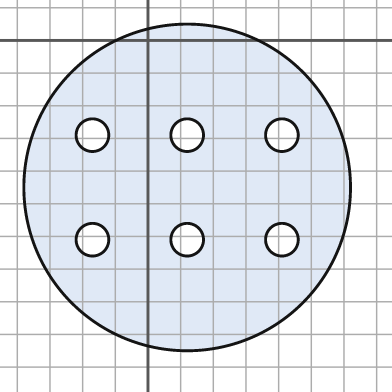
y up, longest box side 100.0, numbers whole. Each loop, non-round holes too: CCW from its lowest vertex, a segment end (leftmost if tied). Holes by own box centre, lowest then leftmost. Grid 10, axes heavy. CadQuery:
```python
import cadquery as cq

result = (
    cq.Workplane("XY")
    .moveTo(12.0, -45.0)
    .circle(50.0)
    .moveTo(-17.0, -61.0)
    .circle(5.0)
    .moveTo(12.0, -61.0)
    .circle(5.0)
    .moveTo(41.0, -61.0)
    .circle(5.0)
    .moveTo(-17.0, -29.0)
    .circle(5.0)
    .moveTo(12.0, -29.0)
    .circle(5.0)
    .moveTo(41.0, -29.0)
    .circle(5.0)
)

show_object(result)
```